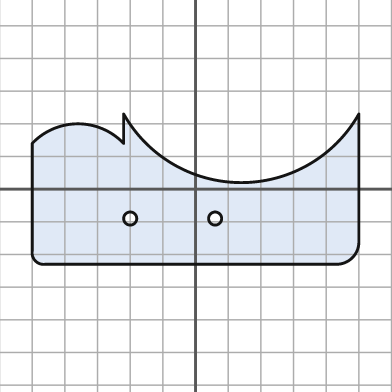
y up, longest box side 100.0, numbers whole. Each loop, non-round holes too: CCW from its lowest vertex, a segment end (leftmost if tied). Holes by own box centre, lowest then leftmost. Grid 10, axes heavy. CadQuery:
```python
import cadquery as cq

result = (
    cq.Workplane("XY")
    .moveTo(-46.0, -23.0)
    .lineTo(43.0, -23.0)
    .threePointArc((48.0, -21.0), (50.0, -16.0))
    .lineTo(50.0, 23.0)
    .threePointArc((14.0, 2.0), (-22.0, 23.0))
    .lineTo(-22.0, 14.0)
    .threePointArc((-36.0, 20.0), (-50.0, 14.0))
    .lineTo(-50.0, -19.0)
    .threePointArc((-49.0, -22.0), (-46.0, -23.0))
    .close()
    .moveTo(-20.0, -9.0)
    .circle(2.0)
    .moveTo(6.0, -9.0)
    .circle(2.0)
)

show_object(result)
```